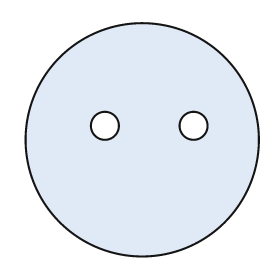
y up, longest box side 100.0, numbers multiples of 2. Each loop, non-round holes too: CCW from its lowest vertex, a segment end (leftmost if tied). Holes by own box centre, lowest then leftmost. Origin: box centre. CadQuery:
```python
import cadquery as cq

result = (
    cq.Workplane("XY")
    .moveTo(0.0, 0.0)
    .circle(50.0)
    .moveTo(-16.0, 6.0)
    .circle(6.0)
    .moveTo(22.0, 6.0)
    .circle(6.0)
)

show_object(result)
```